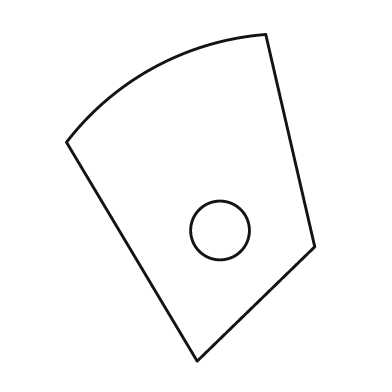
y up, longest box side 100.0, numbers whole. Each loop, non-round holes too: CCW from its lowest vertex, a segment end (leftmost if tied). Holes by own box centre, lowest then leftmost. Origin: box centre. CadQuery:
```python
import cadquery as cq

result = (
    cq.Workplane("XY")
    .moveTo(2.0, -50.0)
    .lineTo(38.0, -15.0)
    .lineTo(23.0, 50.0)
    .threePointArc((-11.0, 40.0), (-38.0, 17.0))
    .close()
    .moveTo(9.0, -10.0)
    .circle(9.0)
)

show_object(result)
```